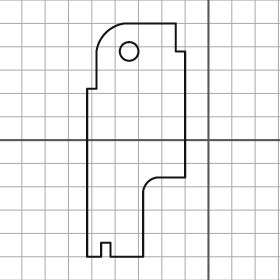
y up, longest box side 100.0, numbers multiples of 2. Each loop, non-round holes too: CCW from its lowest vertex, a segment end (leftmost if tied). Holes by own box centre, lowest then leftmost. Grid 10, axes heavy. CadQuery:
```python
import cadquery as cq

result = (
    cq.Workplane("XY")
    .moveTo(-52.0, -50.0)
    .lineTo(-46.0, -50.0)
    .lineTo(-46.0, -44.0)
    .lineTo(-42.0, -44.0)
    .lineTo(-42.0, -50.0)
    .lineTo(-28.0, -50.0)
    .lineTo(-28.0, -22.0)
    .threePointArc((-26.0, -18.0), (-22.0, -16.0))
    .lineTo(-10.0, -16.0)
    .lineTo(-10.0, 38.0)
    .lineTo(-14.0, 38.0)
    .lineTo(-14.0, 50.0)
    .lineTo(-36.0, 50.0)
    .threePointArc((-44.0, 46.0), (-48.0, 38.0))
    .lineTo(-48.0, 22.0)
    .lineTo(-52.0, 22.0)
    .close()
    .moveTo(-34.0, 38.0)
    .circle(4.0)
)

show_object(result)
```